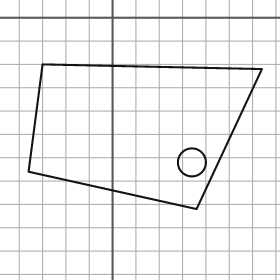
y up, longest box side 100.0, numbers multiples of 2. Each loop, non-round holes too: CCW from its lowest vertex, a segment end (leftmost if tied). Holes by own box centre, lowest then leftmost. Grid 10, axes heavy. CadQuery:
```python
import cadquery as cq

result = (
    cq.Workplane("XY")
    .moveTo(36.0, -82.0)
    .lineTo(64.0, -22.0)
    .lineTo(-30.0, -20.0)
    .lineTo(-36.0, -66.0)
    .close()
    .moveTo(34.0, -62.0)
    .circle(6.0)
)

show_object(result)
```